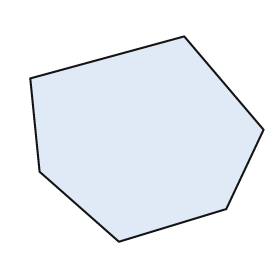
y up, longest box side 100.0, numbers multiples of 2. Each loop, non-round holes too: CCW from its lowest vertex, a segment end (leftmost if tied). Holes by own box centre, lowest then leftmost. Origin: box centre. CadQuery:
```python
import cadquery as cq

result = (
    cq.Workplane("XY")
    .moveTo(-12.0, -44.0)
    .lineTo(34.0, -30.0)
    .lineTo(50.0, 4.0)
    .lineTo(16.0, 44.0)
    .lineTo(-50.0, 26.0)
    .lineTo(-46.0, -14.0)
    .close()
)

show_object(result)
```